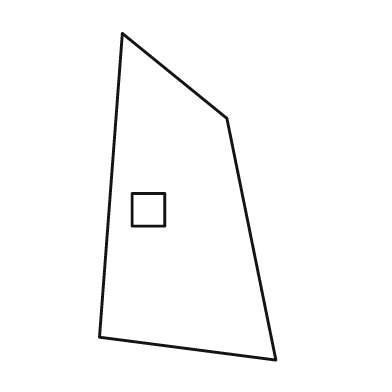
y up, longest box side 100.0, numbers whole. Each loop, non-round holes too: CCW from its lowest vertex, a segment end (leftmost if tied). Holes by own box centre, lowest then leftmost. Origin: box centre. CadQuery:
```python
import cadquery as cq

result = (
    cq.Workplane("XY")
    .moveTo(27.0, -50.0)
    .lineTo(12.0, 24.0)
    .lineTo(-20.0, 50.0)
    .lineTo(-27.0, -43.0)
    .close()
    .moveTo(-17.0, -9.0)
    .lineTo(-7.0, -9.0)
    .lineTo(-7.0, 1.0)
    .lineTo(-17.0, 1.0)
    .close()
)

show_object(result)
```